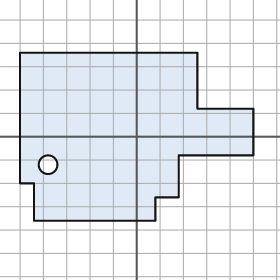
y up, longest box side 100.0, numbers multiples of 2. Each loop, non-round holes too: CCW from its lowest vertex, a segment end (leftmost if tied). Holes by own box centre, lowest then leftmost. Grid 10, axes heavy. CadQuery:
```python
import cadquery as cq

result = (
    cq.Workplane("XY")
    .moveTo(-44.0, -36.0)
    .lineTo(8.0, -36.0)
    .lineTo(8.0, -26.0)
    .lineTo(18.0, -26.0)
    .lineTo(18.0, -8.0)
    .lineTo(50.0, -8.0)
    .lineTo(50.0, 12.0)
    .lineTo(26.0, 12.0)
    .lineTo(26.0, 36.0)
    .lineTo(-50.0, 36.0)
    .lineTo(-50.0, -20.0)
    .lineTo(-44.0, -20.0)
    .close()
    .moveTo(-38.0, -12.0)
    .circle(4.0)
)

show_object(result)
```